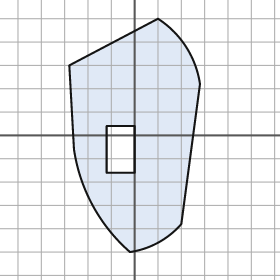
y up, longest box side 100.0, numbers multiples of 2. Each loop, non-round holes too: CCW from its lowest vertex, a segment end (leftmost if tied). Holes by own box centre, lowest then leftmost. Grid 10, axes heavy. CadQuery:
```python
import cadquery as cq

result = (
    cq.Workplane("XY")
    .moveTo(-2.0, -50.0)
    .threePointArc((10.0, -46.0), (20.0, -38.0))
    .lineTo(28.0, 22.0)
    .threePointArc((22.0, 38.0), (10.0, 50.0))
    .lineTo(-28.0, 30.0)
    .lineTo(-26.0, -6.0)
    .threePointArc((-18.0, -30.0), (-2.0, -50.0))
    .close()
    .moveTo(-12.0, -16.0)
    .lineTo(0.0, -16.0)
    .lineTo(0.0, 4.0)
    .lineTo(-12.0, 4.0)
    .close()
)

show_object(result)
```